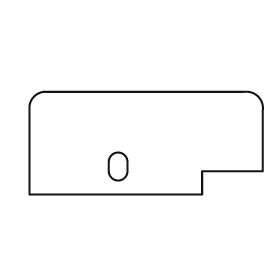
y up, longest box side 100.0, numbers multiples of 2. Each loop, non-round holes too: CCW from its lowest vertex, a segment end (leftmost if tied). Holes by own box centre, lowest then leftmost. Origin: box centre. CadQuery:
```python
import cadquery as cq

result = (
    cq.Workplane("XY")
    .moveTo(-50.0, -22.0)
    .lineTo(24.0, -22.0)
    .lineTo(24.0, -12.0)
    .lineTo(50.0, -12.0)
    .lineTo(50.0, 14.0)
    .threePointArc((48.0, 20.0), (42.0, 22.0))
    .lineTo(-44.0, 22.0)
    .threePointArc((-48.0, 20.0), (-50.0, 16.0))
    .close()
    .moveTo(-16.0, -12.0)
    .threePointArc((-12.0, -16.0), (-8.0, -12.0))
    .lineTo(-8.0, -8.0)
    .threePointArc((-12.0, -4.0), (-16.0, -8.0))
    .close()
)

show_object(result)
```